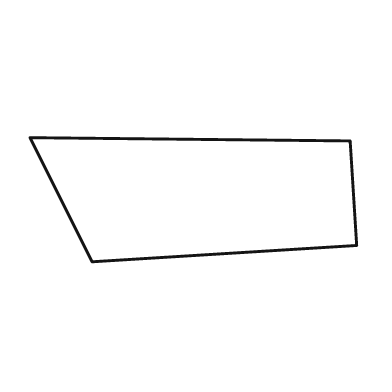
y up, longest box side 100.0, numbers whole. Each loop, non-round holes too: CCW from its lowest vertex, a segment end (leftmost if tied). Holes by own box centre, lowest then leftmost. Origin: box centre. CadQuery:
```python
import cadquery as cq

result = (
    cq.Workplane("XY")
    .moveTo(-31.0, -19.0)
    .lineTo(50.0, -14.0)
    .lineTo(48.0, 18.0)
    .lineTo(-50.0, 19.0)
    .close()
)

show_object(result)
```